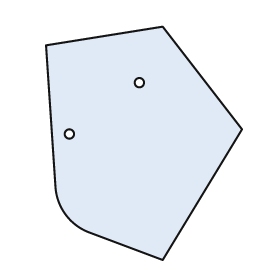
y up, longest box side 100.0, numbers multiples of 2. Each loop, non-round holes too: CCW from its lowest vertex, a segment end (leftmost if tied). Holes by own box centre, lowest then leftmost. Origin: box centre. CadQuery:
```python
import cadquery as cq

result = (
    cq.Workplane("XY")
    .moveTo(8.0, -50.0)
    .lineTo(42.0, 6.0)
    .lineTo(8.0, 50.0)
    .lineTo(-42.0, 42.0)
    .lineTo(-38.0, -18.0)
    .threePointArc((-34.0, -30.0), (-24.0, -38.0))
    .close()
    .moveTo(-32.0, 4.0)
    .circle(2.0)
    .moveTo(-2.0, 26.0)
    .circle(2.0)
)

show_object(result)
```